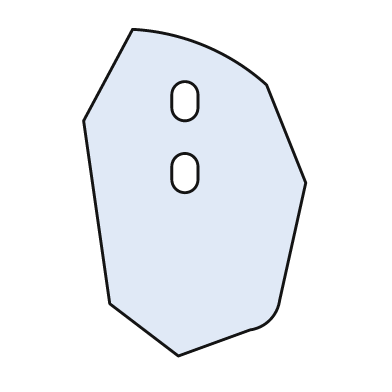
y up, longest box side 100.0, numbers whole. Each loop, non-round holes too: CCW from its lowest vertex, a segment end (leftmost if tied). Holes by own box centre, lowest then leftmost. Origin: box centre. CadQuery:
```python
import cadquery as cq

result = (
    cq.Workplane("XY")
    .moveTo(-5.0, -50.0)
    .lineTo(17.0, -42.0)
    .threePointArc((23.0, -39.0), (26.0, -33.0))
    .lineTo(34.0, 3.0)
    .lineTo(22.0, 33.0)
    .threePointArc((3.0, 45.0), (-19.0, 50.0))
    .lineTo(-34.0, 22.0)
    .lineTo(-26.0, -34.0)
    .close()
    .moveTo(-7.0, 4.0)
    .threePointArc((-3.0, 0.0), (1.0, 4.0))
    .lineTo(1.0, 8.0)
    .threePointArc((-3.0, 12.0), (-7.0, 8.0))
    .close()
    .moveTo(-7.0, 26.0)
    .threePointArc((-3.0, 22.0), (1.0, 26.0))
    .lineTo(1.0, 30.0)
    .threePointArc((-3.0, 34.0), (-7.0, 30.0))
    .close()
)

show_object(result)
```